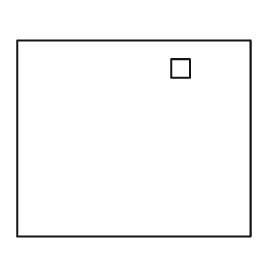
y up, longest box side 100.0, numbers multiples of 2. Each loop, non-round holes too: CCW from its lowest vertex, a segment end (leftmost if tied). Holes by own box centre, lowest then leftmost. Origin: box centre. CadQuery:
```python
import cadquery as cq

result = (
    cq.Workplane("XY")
    .moveTo(-50.0, -42.0)
    .lineTo(50.0, -42.0)
    .lineTo(50.0, 42.0)
    .lineTo(-50.0, 42.0)
    .close()
    .moveTo(16.0, 26.0)
    .lineTo(24.0, 26.0)
    .lineTo(24.0, 34.0)
    .lineTo(16.0, 34.0)
    .close()
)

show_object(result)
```